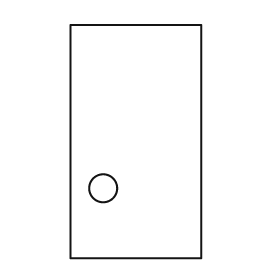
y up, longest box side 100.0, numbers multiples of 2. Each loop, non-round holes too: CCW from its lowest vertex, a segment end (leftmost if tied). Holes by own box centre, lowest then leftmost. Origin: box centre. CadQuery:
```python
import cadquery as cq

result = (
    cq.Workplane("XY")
    .moveTo(-28.0, -50.0)
    .lineTo(28.0, -50.0)
    .lineTo(28.0, 50.0)
    .lineTo(-28.0, 50.0)
    .close()
    .moveTo(-14.0, -20.0)
    .circle(6.0)
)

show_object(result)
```